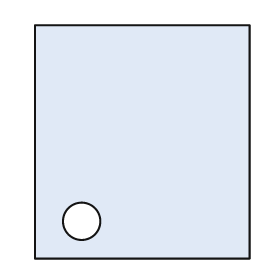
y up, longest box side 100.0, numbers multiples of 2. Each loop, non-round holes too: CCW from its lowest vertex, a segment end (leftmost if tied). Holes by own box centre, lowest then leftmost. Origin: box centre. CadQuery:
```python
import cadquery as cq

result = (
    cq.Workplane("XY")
    .moveTo(-46.0, -50.0)
    .lineTo(46.0, -50.0)
    .lineTo(46.0, 50.0)
    .lineTo(-46.0, 50.0)
    .close()
    .moveTo(-26.0, -34.0)
    .circle(8.0)
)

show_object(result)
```